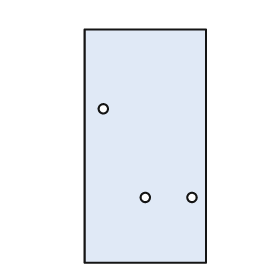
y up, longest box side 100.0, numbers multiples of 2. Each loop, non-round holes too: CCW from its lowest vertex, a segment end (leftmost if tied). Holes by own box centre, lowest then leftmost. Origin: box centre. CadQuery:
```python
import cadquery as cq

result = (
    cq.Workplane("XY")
    .moveTo(-26.0, -50.0)
    .lineTo(26.0, -50.0)
    .lineTo(26.0, 50.0)
    .lineTo(-26.0, 50.0)
    .close()
    .moveTo(0.0, -22.0)
    .circle(2.0)
    .moveTo(20.0, -22.0)
    .circle(2.0)
    .moveTo(-18.0, 16.0)
    .circle(2.0)
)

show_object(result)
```